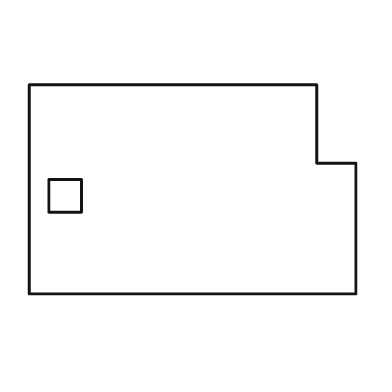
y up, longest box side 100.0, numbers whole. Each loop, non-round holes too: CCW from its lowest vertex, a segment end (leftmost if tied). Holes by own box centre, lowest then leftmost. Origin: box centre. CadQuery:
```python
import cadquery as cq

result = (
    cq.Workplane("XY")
    .moveTo(-50.0, -32.0)
    .lineTo(50.0, -32.0)
    .lineTo(50.0, 8.0)
    .lineTo(38.0, 8.0)
    .lineTo(38.0, 32.0)
    .lineTo(-50.0, 32.0)
    .close()
    .moveTo(-44.0, -7.0)
    .lineTo(-34.0, -7.0)
    .lineTo(-34.0, 3.0)
    .lineTo(-44.0, 3.0)
    .close()
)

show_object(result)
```